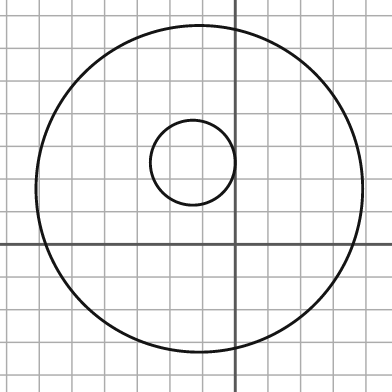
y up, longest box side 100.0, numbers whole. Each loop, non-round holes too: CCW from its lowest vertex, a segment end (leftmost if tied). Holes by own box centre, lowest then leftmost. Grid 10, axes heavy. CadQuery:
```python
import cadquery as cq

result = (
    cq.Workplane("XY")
    .moveTo(-11.0, 17.0)
    .circle(50.0)
    .moveTo(-13.0, 25.0)
    .circle(13.0)
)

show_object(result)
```